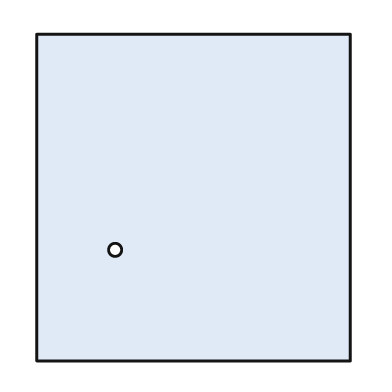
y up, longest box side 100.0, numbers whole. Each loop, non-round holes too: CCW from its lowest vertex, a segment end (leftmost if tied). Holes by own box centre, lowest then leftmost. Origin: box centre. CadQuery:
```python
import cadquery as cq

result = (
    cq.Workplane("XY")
    .moveTo(-48.0, -50.0)
    .lineTo(48.0, -50.0)
    .lineTo(48.0, 50.0)
    .lineTo(-48.0, 50.0)
    .close()
    .moveTo(-24.0, -16.0)
    .circle(2.0)
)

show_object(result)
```